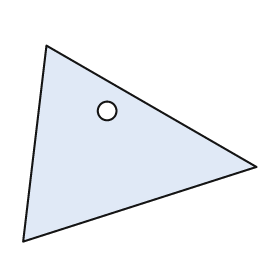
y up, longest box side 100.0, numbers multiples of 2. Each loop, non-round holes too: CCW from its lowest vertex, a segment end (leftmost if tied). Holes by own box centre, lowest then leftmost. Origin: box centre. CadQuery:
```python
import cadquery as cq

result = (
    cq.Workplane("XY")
    .moveTo(-50.0, -42.0)
    .lineTo(50.0, -10.0)
    .lineTo(-40.0, 42.0)
    .close()
    .moveTo(-14.0, 14.0)
    .circle(4.0)
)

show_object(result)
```